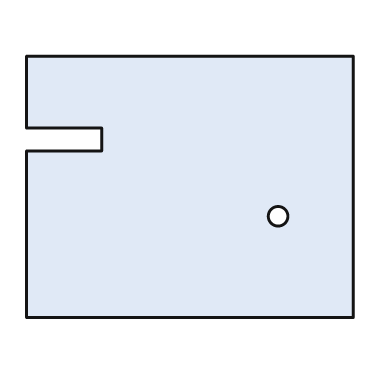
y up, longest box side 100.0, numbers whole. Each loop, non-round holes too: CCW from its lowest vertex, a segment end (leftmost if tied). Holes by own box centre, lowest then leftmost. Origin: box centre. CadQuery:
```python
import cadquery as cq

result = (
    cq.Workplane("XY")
    .moveTo(-50.0, -40.0)
    .lineTo(50.0, -40.0)
    .lineTo(50.0, 40.0)
    .lineTo(-50.0, 40.0)
    .lineTo(-50.0, 18.0)
    .lineTo(-27.0, 18.0)
    .lineTo(-27.0, 11.0)
    .lineTo(-50.0, 11.0)
    .close()
    .moveTo(27.0, -9.0)
    .circle(3.0)
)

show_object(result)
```